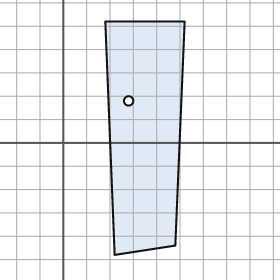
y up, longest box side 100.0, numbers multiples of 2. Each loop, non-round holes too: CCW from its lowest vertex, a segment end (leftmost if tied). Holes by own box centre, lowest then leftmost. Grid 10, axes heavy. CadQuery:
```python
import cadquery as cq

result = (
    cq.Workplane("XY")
    .moveTo(22.0, -48.0)
    .lineTo(48.0, -44.0)
    .lineTo(52.0, 52.0)
    .lineTo(18.0, 52.0)
    .close()
    .moveTo(28.0, 18.0)
    .circle(2.0)
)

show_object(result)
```